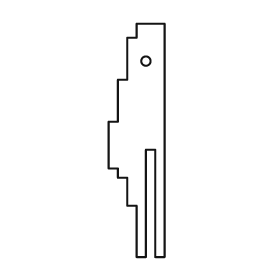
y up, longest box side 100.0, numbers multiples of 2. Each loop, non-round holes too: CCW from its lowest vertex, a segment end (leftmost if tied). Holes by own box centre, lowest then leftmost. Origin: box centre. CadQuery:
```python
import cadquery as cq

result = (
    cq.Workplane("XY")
    .moveTo(0.0, -50.0)
    .lineTo(4.0, -50.0)
    .lineTo(4.0, -4.0)
    .lineTo(8.0, -4.0)
    .lineTo(8.0, -50.0)
    .lineTo(12.0, -50.0)
    .lineTo(12.0, 50.0)
    .lineTo(0.0, 50.0)
    .lineTo(0.0, 44.0)
    .lineTo(-4.0, 44.0)
    .lineTo(-4.0, 26.0)
    .lineTo(-8.0, 26.0)
    .lineTo(-8.0, 8.0)
    .lineTo(-12.0, 8.0)
    .lineTo(-12.0, -12.0)
    .lineTo(-8.0, -12.0)
    .lineTo(-8.0, -16.0)
    .lineTo(-4.0, -16.0)
    .lineTo(-4.0, -28.0)
    .lineTo(0.0, -28.0)
    .close()
    .moveTo(4.0, 34.0)
    .circle(2.0)
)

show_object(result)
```